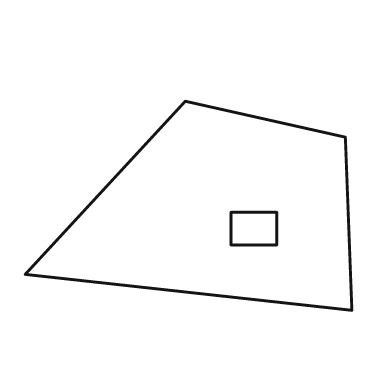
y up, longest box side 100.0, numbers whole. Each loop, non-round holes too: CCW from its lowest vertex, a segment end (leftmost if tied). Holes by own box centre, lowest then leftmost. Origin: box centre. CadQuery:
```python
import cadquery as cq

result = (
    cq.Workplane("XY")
    .moveTo(50.0, -32.0)
    .lineTo(48.0, 21.0)
    .lineTo(-1.0, 32.0)
    .lineTo(-50.0, -21.0)
    .close()
    .moveTo(13.0, -12.0)
    .lineTo(27.0, -12.0)
    .lineTo(27.0, -2.0)
    .lineTo(13.0, -2.0)
    .close()
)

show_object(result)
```